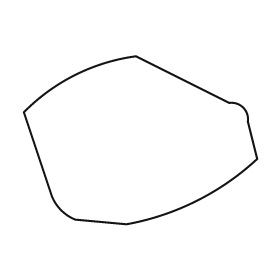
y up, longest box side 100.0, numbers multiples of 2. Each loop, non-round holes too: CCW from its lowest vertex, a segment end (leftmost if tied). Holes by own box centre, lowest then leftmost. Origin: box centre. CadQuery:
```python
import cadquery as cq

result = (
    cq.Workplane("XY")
    .moveTo(-6.0, -36.0)
    .threePointArc((24.0, -26.0), (50.0, -8.0))
    .lineTo(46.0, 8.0)
    .threePointArc((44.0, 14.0), (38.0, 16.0))
    .lineTo(-2.0, 36.0)
    .threePointArc((-28.0, 28.0), (-50.0, 12.0))
    .lineTo(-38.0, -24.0)
    .threePointArc((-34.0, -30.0), (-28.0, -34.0))
    .close()
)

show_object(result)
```